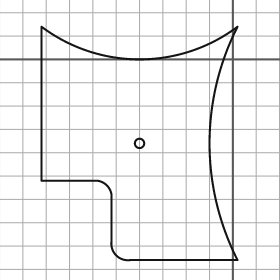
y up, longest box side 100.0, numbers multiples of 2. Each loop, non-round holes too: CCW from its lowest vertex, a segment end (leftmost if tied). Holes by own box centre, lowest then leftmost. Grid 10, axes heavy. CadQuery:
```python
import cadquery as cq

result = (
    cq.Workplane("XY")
    .moveTo(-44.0, -86.0)
    .lineTo(2.0, -86.0)
    .threePointArc((-10.0, -36.0), (2.0, 14.0))
    .threePointArc((-40.0, 0.0), (-82.0, 14.0))
    .lineTo(-82.0, -52.0)
    .lineTo(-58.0, -52.0)
    .threePointArc((-54.0, -54.0), (-52.0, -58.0))
    .lineTo(-52.0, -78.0)
    .threePointArc((-50.0, -84.0), (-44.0, -86.0))
    .close()
    .moveTo(-40.0, -36.0)
    .circle(2.0)
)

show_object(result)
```